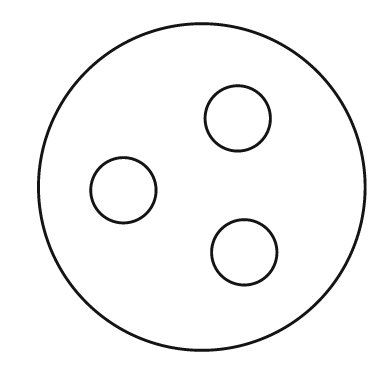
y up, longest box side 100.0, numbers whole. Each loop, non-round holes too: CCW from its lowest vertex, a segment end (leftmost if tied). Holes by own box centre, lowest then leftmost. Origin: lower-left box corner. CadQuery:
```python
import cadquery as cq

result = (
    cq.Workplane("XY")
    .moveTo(50.0, 50.0)
    .circle(50.0)
    .moveTo(63.0, 30.0)
    .circle(10.0)
    .moveTo(26.0, 49.0)
    .circle(10.0)
    .moveTo(61.0, 71.0)
    .circle(10.0)
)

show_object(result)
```